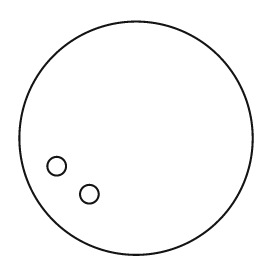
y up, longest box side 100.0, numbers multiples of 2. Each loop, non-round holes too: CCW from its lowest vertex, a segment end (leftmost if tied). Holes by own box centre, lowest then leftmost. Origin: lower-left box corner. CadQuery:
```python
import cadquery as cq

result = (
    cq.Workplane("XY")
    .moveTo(50.0, 50.0)
    .circle(50.0)
    .moveTo(30.0, 26.0)
    .circle(4.0)
    .moveTo(16.0, 38.0)
    .circle(4.0)
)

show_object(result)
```